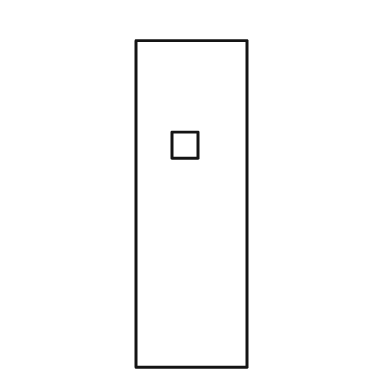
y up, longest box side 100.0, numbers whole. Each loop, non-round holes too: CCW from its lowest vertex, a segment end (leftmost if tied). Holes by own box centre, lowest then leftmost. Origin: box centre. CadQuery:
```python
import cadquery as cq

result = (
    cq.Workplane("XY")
    .moveTo(-17.0, -50.0)
    .lineTo(17.0, -50.0)
    .lineTo(17.0, 50.0)
    .lineTo(-17.0, 50.0)
    .close()
    .moveTo(-6.0, 14.0)
    .lineTo(2.0, 14.0)
    .lineTo(2.0, 22.0)
    .lineTo(-6.0, 22.0)
    .close()
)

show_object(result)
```